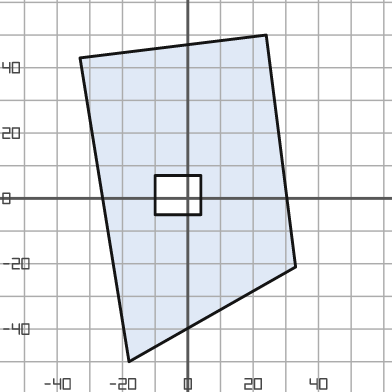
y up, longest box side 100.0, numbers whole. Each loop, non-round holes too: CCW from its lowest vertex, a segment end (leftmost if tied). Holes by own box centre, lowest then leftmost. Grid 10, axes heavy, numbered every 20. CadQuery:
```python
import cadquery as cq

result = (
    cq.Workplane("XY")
    .moveTo(-18.0, -50.0)
    .lineTo(33.0, -21.0)
    .lineTo(24.0, 50.0)
    .lineTo(-33.0, 43.0)
    .close()
    .moveTo(-10.0, -5.0)
    .lineTo(4.0, -5.0)
    .lineTo(4.0, 7.0)
    .lineTo(-10.0, 7.0)
    .close()
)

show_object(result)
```